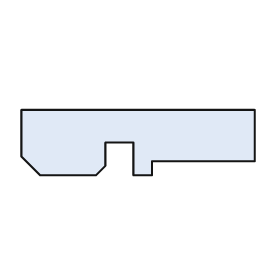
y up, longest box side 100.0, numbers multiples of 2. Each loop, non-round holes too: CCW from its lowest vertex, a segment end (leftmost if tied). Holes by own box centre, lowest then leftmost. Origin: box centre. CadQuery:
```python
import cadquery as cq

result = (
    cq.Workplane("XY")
    .moveTo(-42.0, -14.0)
    .lineTo(-18.0, -14.0)
    .lineTo(-14.0, -10.0)
    .lineTo(-14.0, 0.0)
    .lineTo(-2.0, 0.0)
    .lineTo(-2.0, -14.0)
    .lineTo(6.0, -14.0)
    .lineTo(6.0, -8.0)
    .lineTo(50.0, -8.0)
    .lineTo(50.0, 14.0)
    .lineTo(-50.0, 14.0)
    .lineTo(-50.0, -6.0)
    .close()
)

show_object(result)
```